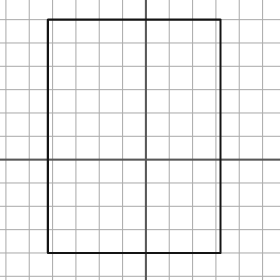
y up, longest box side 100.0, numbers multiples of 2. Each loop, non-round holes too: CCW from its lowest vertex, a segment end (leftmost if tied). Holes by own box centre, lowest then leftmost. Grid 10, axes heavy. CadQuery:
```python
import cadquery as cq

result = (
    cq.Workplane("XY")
    .moveTo(-42.0, -40.0)
    .lineTo(32.0, -40.0)
    .lineTo(32.0, 60.0)
    .lineTo(-42.0, 60.0)
    .close()
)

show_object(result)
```